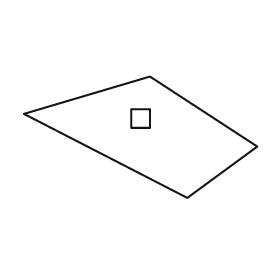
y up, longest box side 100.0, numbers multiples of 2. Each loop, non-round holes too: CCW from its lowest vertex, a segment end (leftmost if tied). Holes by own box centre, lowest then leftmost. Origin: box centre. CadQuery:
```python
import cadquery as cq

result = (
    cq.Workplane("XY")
    .moveTo(20.0, -26.0)
    .lineTo(50.0, -4.0)
    .lineTo(4.0, 26.0)
    .lineTo(-50.0, 10.0)
    .close()
    .moveTo(-4.0, 4.0)
    .lineTo(4.0, 4.0)
    .lineTo(4.0, 12.0)
    .lineTo(-4.0, 12.0)
    .close()
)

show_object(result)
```